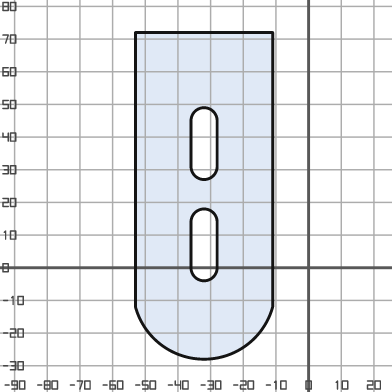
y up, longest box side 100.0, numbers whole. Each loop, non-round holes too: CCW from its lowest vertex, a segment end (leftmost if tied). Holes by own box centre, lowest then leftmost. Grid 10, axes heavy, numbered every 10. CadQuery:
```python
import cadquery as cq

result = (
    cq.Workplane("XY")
    .moveTo(-53.0, -12.0)
    .threePointArc((-32.0, -28.0), (-11.0, -12.0))
    .lineTo(-11.0, 72.0)
    .lineTo(-53.0, 72.0)
    .close()
    .moveTo(-36.0, 0.0)
    .threePointArc((-32.0, -4.0), (-28.0, 0.0))
    .lineTo(-28.0, 14.0)
    .threePointArc((-32.0, 18.0), (-36.0, 14.0))
    .close()
    .moveTo(-36.0, 31.0)
    .threePointArc((-32.0, 27.0), (-28.0, 31.0))
    .lineTo(-28.0, 45.0)
    .threePointArc((-32.0, 49.0), (-36.0, 45.0))
    .close()
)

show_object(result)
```